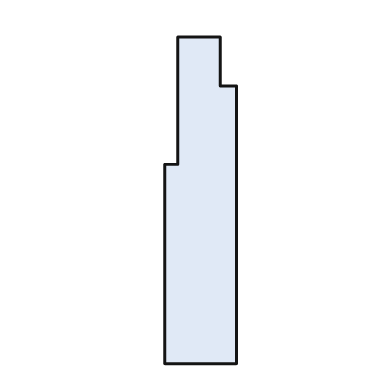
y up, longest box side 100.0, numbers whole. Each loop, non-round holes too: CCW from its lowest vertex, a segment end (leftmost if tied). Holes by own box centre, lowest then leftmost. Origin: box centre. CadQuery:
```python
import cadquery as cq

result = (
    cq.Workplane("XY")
    .moveTo(-11.0, -50.0)
    .lineTo(11.0, -50.0)
    .lineTo(11.0, 35.0)
    .lineTo(6.0, 35.0)
    .lineTo(6.0, 50.0)
    .lineTo(-7.0, 50.0)
    .lineTo(-7.0, 11.0)
    .lineTo(-11.0, 11.0)
    .close()
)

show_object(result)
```